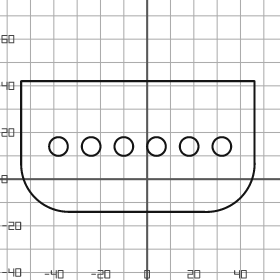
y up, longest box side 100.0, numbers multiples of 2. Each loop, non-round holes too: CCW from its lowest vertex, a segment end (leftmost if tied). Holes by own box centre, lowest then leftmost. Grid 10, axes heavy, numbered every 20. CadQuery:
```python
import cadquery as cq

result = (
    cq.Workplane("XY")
    .moveTo(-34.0, -14.0)
    .lineTo(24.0, -14.0)
    .threePointArc((40.0, -8.0), (46.0, 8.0))
    .lineTo(46.0, 42.0)
    .lineTo(-54.0, 42.0)
    .lineTo(-54.0, 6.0)
    .threePointArc((-48.0, -8.0), (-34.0, -14.0))
    .close()
    .moveTo(-38.0, 14.0)
    .circle(4.0)
    .moveTo(-24.0, 14.0)
    .circle(4.0)
    .moveTo(-10.0, 14.0)
    .circle(4.0)
    .moveTo(4.0, 14.0)
    .circle(4.0)
    .moveTo(18.0, 14.0)
    .circle(4.0)
    .moveTo(32.0, 14.0)
    .circle(4.0)
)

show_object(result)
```